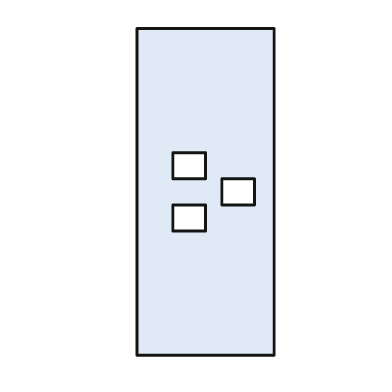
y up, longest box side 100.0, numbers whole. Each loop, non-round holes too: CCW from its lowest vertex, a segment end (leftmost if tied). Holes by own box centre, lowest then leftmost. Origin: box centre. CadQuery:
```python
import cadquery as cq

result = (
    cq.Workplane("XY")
    .moveTo(-21.0, -50.0)
    .lineTo(21.0, -50.0)
    .lineTo(21.0, 50.0)
    .lineTo(-21.0, 50.0)
    .close()
    .moveTo(-10.0, -12.0)
    .lineTo(0.0, -12.0)
    .lineTo(0.0, -4.0)
    .lineTo(-10.0, -4.0)
    .close()
    .moveTo(5.0, -4.0)
    .lineTo(15.0, -4.0)
    .lineTo(15.0, 4.0)
    .lineTo(5.0, 4.0)
    .close()
    .moveTo(-10.0, 4.0)
    .lineTo(0.0, 4.0)
    .lineTo(0.0, 12.0)
    .lineTo(-10.0, 12.0)
    .close()
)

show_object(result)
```